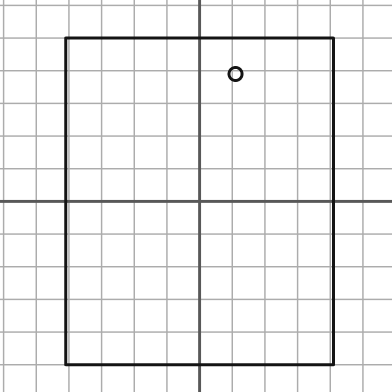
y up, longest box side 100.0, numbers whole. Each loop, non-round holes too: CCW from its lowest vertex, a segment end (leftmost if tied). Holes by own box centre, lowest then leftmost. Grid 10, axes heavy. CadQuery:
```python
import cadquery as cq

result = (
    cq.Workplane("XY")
    .moveTo(-41.0, -50.0)
    .lineTo(41.0, -50.0)
    .lineTo(41.0, 50.0)
    .lineTo(-41.0, 50.0)
    .close()
    .moveTo(11.0, 39.0)
    .circle(2.0)
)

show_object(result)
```